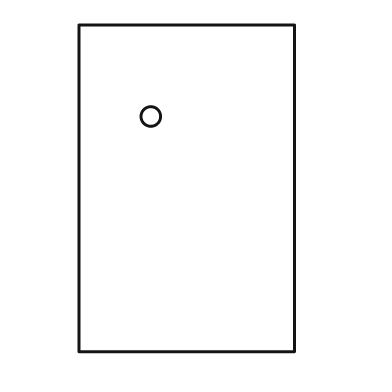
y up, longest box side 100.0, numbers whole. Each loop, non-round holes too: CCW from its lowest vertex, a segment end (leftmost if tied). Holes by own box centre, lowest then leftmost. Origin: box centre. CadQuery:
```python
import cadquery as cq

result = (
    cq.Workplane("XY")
    .moveTo(-33.0, -50.0)
    .lineTo(33.0, -50.0)
    .lineTo(33.0, 50.0)
    .lineTo(-33.0, 50.0)
    .close()
    .moveTo(-11.0, 22.0)
    .circle(3.0)
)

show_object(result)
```